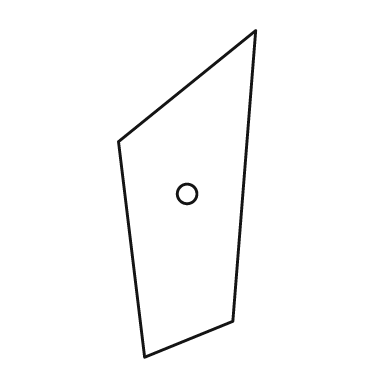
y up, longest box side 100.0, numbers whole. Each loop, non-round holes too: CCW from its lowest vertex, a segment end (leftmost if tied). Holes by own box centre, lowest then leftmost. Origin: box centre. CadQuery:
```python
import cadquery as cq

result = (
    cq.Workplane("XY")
    .moveTo(-13.0, -50.0)
    .lineTo(14.0, -39.0)
    .lineTo(21.0, 50.0)
    .lineTo(-21.0, 16.0)
    .close()
    .moveTo(0.0, 0.0)
    .circle(3.0)
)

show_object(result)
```